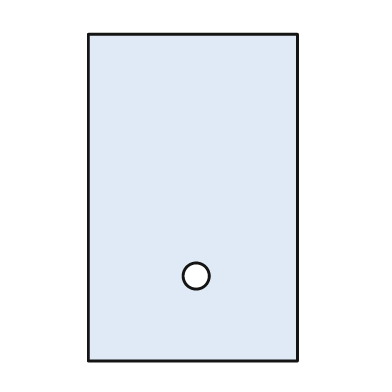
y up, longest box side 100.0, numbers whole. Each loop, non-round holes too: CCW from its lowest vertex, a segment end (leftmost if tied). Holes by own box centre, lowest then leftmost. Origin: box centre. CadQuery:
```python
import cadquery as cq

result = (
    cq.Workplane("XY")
    .moveTo(-32.0, -50.0)
    .lineTo(32.0, -50.0)
    .lineTo(32.0, 50.0)
    .lineTo(-32.0, 50.0)
    .close()
    .moveTo(1.0, -24.0)
    .circle(4.0)
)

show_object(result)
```